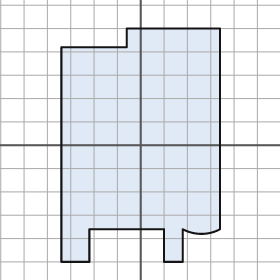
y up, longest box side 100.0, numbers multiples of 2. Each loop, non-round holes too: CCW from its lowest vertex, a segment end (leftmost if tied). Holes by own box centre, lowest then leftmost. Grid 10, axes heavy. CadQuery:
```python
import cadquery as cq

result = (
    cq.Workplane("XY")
    .moveTo(-34.0, -50.0)
    .lineTo(-22.0, -50.0)
    .lineTo(-22.0, -36.0)
    .lineTo(10.0, -36.0)
    .lineTo(10.0, -50.0)
    .lineTo(18.0, -50.0)
    .lineTo(18.0, -36.0)
    .threePointArc((26.0, -38.0), (34.0, -36.0))
    .lineTo(34.0, 50.0)
    .lineTo(-6.0, 50.0)
    .lineTo(-6.0, 42.0)
    .lineTo(-34.0, 42.0)
    .close()
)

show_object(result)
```